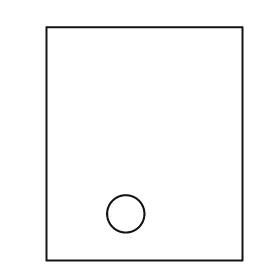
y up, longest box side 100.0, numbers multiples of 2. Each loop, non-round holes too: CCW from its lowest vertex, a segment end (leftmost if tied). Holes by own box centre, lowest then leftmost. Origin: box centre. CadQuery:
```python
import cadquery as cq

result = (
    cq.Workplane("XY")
    .moveTo(-42.0, -50.0)
    .lineTo(42.0, -50.0)
    .lineTo(42.0, 50.0)
    .lineTo(-42.0, 50.0)
    .close()
    .moveTo(-8.0, -30.0)
    .circle(8.0)
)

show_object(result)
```